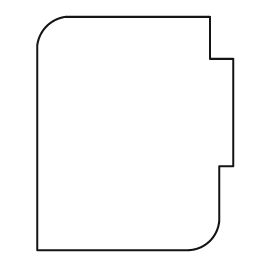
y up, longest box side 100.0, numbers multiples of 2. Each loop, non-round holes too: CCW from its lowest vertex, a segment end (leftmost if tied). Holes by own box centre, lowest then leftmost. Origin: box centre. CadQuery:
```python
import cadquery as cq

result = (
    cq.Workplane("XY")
    .moveTo(-42.0, -50.0)
    .lineTo(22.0, -50.0)
    .threePointArc((32.0, -46.0), (36.0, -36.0))
    .lineTo(36.0, -14.0)
    .lineTo(42.0, -14.0)
    .lineTo(42.0, 32.0)
    .lineTo(32.0, 32.0)
    .lineTo(32.0, 50.0)
    .lineTo(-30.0, 50.0)
    .threePointArc((-38.0, 46.0), (-42.0, 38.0))
    .close()
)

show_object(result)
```